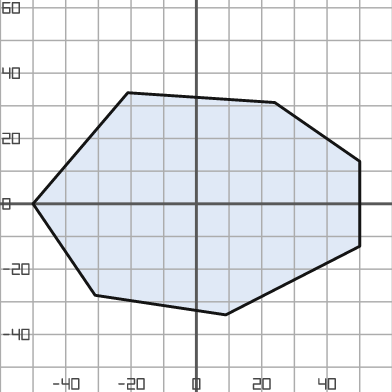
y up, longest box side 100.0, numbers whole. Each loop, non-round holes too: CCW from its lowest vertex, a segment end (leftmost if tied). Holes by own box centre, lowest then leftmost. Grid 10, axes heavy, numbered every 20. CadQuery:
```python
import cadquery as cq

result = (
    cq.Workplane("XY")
    .moveTo(9.0, -34.0)
    .lineTo(50.0, -13.0)
    .lineTo(50.0, 13.0)
    .lineTo(24.0, 31.0)
    .lineTo(-21.0, 34.0)
    .lineTo(-50.0, 0.0)
    .lineTo(-31.0, -28.0)
    .close()
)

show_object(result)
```